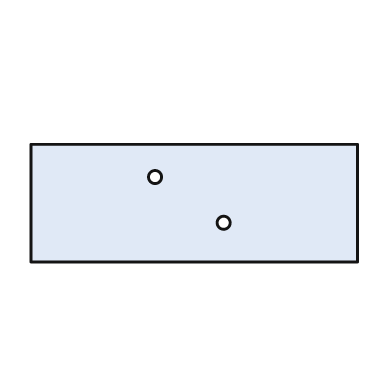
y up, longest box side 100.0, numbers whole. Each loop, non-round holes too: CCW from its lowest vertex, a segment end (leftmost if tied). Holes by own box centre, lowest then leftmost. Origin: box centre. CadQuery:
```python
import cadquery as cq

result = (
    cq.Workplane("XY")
    .moveTo(-50.0, -18.0)
    .lineTo(50.0, -18.0)
    .lineTo(50.0, 18.0)
    .lineTo(-50.0, 18.0)
    .close()
    .moveTo(9.0, -6.0)
    .circle(2.0)
    .moveTo(-12.0, 8.0)
    .circle(2.0)
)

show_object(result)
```